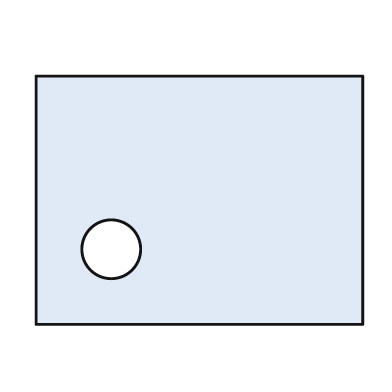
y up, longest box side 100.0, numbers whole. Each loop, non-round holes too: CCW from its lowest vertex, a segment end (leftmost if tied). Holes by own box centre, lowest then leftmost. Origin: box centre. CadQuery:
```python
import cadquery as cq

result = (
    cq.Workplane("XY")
    .moveTo(-50.0, -38.0)
    .lineTo(50.0, -38.0)
    .lineTo(50.0, 38.0)
    .lineTo(-50.0, 38.0)
    .close()
    .moveTo(-27.0, -15.0)
    .circle(9.0)
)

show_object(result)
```